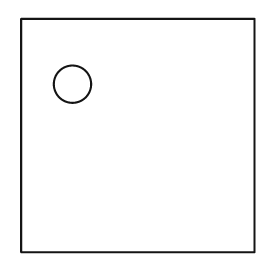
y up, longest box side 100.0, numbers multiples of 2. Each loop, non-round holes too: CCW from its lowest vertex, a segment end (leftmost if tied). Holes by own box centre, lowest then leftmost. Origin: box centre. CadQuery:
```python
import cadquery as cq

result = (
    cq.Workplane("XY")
    .moveTo(-50.0, -50.0)
    .lineTo(50.0, -50.0)
    .lineTo(50.0, 50.0)
    .lineTo(-50.0, 50.0)
    .close()
    .moveTo(-28.0, 22.0)
    .circle(8.0)
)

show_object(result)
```